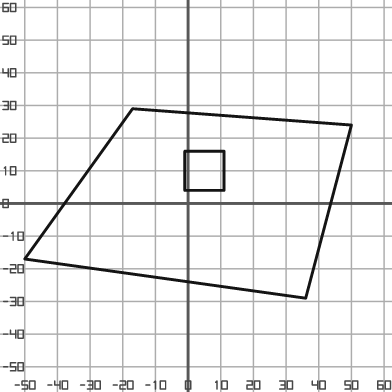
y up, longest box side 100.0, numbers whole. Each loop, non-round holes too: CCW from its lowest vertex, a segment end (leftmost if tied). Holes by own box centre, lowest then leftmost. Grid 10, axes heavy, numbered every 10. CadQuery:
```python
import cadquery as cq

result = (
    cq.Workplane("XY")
    .moveTo(36.0, -29.0)
    .lineTo(50.0, 24.0)
    .lineTo(-17.0, 29.0)
    .lineTo(-50.0, -17.0)
    .close()
    .moveTo(-1.0, 4.0)
    .lineTo(11.0, 4.0)
    .lineTo(11.0, 16.0)
    .lineTo(-1.0, 16.0)
    .close()
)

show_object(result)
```